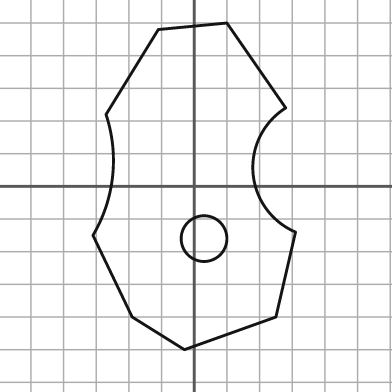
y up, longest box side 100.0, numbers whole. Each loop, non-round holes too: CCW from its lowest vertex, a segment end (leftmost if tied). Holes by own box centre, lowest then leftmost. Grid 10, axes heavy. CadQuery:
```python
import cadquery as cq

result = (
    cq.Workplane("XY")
    .moveTo(-3.0, -50.0)
    .lineTo(25.0, -40.0)
    .lineTo(31.0, -14.0)
    .threePointArc((18.0, 4.0), (28.0, 24.0))
    .lineTo(10.0, 50.0)
    .lineTo(-11.0, 48.0)
    .lineTo(-27.0, 22.0)
    .threePointArc((-25.0, 3.0), (-31.0, -15.0))
    .lineTo(-19.0, -40.0)
    .close()
    .moveTo(3.0, -16.0)
    .circle(7.0)
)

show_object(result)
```